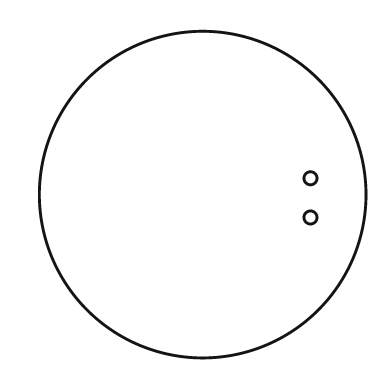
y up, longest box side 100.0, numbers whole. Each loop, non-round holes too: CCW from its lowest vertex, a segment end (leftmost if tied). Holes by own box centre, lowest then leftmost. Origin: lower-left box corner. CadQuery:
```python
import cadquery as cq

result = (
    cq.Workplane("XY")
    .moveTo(50.0, 50.0)
    .circle(50.0)
    .moveTo(83.0, 43.0)
    .circle(2.0)
    .moveTo(83.0, 55.0)
    .circle(2.0)
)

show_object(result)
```